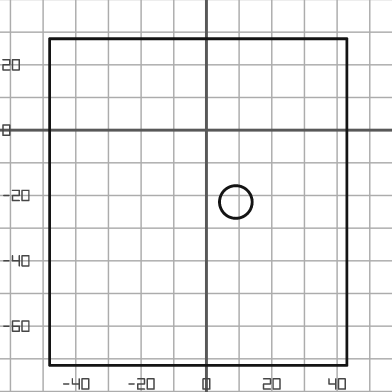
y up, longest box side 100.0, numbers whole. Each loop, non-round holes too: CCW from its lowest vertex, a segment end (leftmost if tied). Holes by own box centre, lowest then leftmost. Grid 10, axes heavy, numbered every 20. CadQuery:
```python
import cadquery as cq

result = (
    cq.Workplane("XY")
    .moveTo(-48.0, -72.0)
    .lineTo(43.0, -72.0)
    .lineTo(43.0, 28.0)
    .lineTo(-48.0, 28.0)
    .close()
    .moveTo(9.0, -22.0)
    .circle(5.0)
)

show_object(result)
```